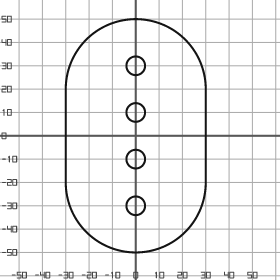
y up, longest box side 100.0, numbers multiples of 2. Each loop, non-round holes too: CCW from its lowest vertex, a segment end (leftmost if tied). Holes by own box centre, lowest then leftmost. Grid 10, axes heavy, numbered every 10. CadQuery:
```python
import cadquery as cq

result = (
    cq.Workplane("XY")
    .moveTo(-30.0, -20.0)
    .threePointArc((0.0, -50.0), (30.0, -20.0))
    .lineTo(30.0, 20.0)
    .threePointArc((0.0, 50.0), (-30.0, 20.0))
    .close()
    .moveTo(0.0, -30.0)
    .circle(4.0)
    .moveTo(0.0, -10.0)
    .circle(4.0)
    .moveTo(0.0, 10.0)
    .circle(4.0)
    .moveTo(0.0, 30.0)
    .circle(4.0)
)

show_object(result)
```